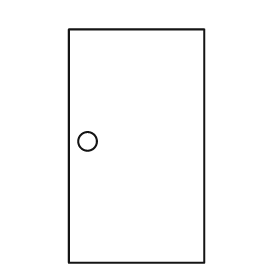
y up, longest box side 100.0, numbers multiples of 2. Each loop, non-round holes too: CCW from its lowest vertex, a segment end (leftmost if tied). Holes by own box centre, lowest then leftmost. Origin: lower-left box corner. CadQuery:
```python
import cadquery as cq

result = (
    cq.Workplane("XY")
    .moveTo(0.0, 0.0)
    .lineTo(58.0, 0.0)
    .lineTo(58.0, 100.0)
    .lineTo(0.0, 100.0)
    .close()
    .moveTo(8.0, 52.0)
    .circle(4.0)
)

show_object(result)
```